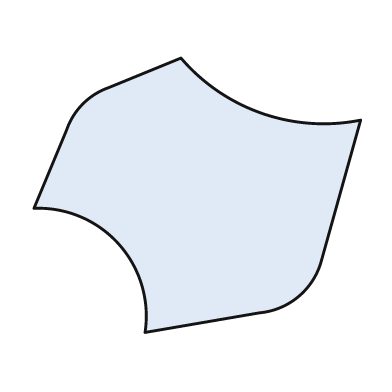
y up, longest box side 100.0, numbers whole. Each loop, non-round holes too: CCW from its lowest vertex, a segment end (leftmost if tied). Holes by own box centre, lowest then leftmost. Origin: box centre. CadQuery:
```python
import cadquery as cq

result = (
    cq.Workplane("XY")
    .moveTo(-16.0, -42.0)
    .lineTo(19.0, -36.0)
    .threePointArc((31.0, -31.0), (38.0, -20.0))
    .lineTo(50.0, 23.0)
    .threePointArc((20.0, 25.0), (-5.0, 42.0))
    .lineTo(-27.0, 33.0)
    .threePointArc((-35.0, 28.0), (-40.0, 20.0))
    .lineTo(-50.0, -4.0)
    .threePointArc((-24.0, -15.0), (-16.0, -42.0))
    .close()
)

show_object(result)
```